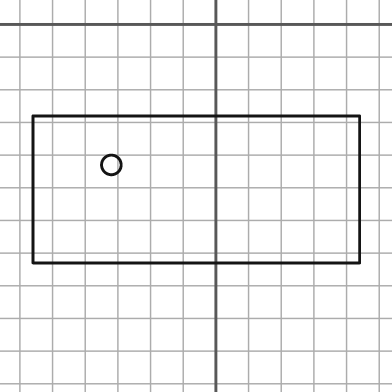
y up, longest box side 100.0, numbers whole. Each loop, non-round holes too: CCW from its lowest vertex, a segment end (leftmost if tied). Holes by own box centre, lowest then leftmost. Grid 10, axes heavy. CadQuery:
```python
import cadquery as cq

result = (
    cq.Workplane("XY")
    .moveTo(-56.0, -73.0)
    .lineTo(44.0, -73.0)
    .lineTo(44.0, -28.0)
    .lineTo(-56.0, -28.0)
    .close()
    .moveTo(-32.0, -43.0)
    .circle(3.0)
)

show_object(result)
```